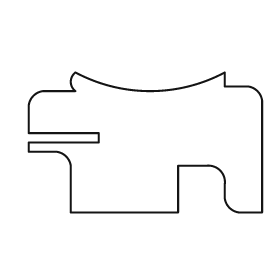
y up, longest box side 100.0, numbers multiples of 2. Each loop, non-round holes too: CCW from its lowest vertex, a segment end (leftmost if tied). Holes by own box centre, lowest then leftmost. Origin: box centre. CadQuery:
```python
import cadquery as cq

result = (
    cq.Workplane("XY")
    .moveTo(-32.0, -30.0)
    .lineTo(14.0, -30.0)
    .lineTo(14.0, -10.0)
    .lineTo(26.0, -10.0)
    .threePointArc((32.0, -12.0), (34.0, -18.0))
    .lineTo(34.0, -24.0)
    .threePointArc((36.0, -28.0), (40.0, -30.0))
    .lineTo(50.0, -30.0)
    .lineTo(50.0, 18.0)
    .threePointArc((48.0, 22.0), (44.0, 24.0))
    .lineTo(34.0, 24.0)
    .lineTo(34.0, 30.0)
    .threePointArc((2.0, 22.0), (-30.0, 30.0))
    .threePointArc((-32.0, 26.0), (-30.0, 22.0))
    .lineTo(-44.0, 22.0)
    .threePointArc((-48.0, 20.0), (-50.0, 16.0))
    .lineTo(-50.0, 4.0)
    .lineTo(-20.0, 4.0)
    .lineTo(-20.0, 0.0)
    .lineTo(-50.0, 0.0)
    .lineTo(-50.0, -4.0)
    .lineTo(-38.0, -4.0)
    .threePointArc((-34.0, -6.0), (-32.0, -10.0))
    .close()
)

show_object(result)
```